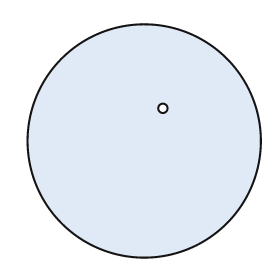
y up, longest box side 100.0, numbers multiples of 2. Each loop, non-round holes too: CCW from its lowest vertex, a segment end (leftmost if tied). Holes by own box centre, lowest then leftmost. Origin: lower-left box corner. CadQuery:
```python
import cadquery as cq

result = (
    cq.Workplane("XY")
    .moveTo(50.0, 50.0)
    .circle(50.0)
    .moveTo(58.0, 64.0)
    .circle(2.0)
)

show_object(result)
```